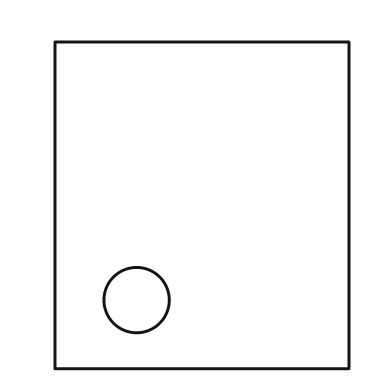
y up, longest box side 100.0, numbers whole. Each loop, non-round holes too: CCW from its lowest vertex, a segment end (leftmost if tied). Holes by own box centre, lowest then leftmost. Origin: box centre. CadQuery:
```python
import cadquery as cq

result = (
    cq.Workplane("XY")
    .moveTo(-45.0, -50.0)
    .lineTo(45.0, -50.0)
    .lineTo(45.0, 50.0)
    .lineTo(-45.0, 50.0)
    .close()
    .moveTo(-20.0, -29.0)
    .circle(10.0)
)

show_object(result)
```